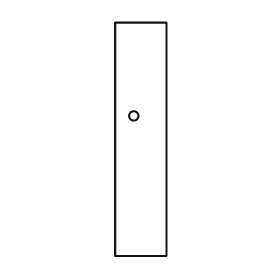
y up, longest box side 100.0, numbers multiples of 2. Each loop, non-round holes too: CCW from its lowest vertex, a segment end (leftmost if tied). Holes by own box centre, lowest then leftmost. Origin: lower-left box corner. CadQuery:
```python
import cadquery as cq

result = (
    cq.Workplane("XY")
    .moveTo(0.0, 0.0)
    .lineTo(22.0, 0.0)
    .lineTo(22.0, 100.0)
    .lineTo(0.0, 100.0)
    .close()
    .moveTo(8.0, 60.0)
    .circle(2.0)
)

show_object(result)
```